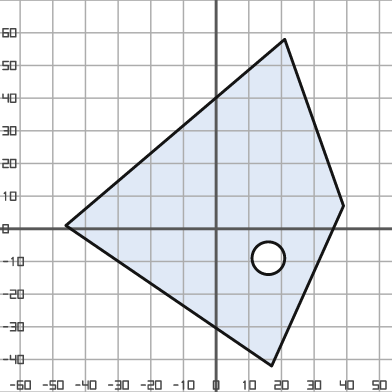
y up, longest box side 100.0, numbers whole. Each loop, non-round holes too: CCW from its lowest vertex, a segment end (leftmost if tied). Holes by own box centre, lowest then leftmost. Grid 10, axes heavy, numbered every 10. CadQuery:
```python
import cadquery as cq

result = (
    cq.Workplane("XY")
    .moveTo(17.0, -42.0)
    .lineTo(39.0, 7.0)
    .lineTo(21.0, 58.0)
    .lineTo(-46.0, 1.0)
    .close()
    .moveTo(16.0, -9.0)
    .circle(5.0)
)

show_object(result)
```